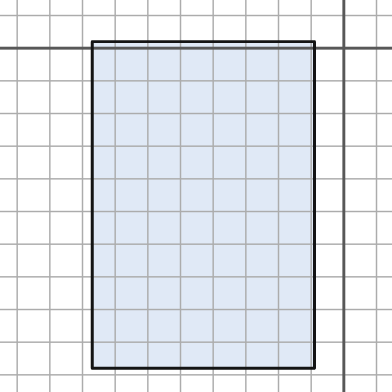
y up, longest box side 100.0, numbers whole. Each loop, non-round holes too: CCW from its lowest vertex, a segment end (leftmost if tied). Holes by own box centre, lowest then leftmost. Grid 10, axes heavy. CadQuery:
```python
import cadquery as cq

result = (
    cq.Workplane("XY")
    .moveTo(-77.0, -98.0)
    .lineTo(-9.0, -98.0)
    .lineTo(-9.0, 2.0)
    .lineTo(-77.0, 2.0)
    .close()
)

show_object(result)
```